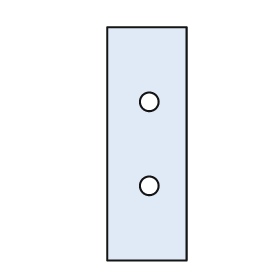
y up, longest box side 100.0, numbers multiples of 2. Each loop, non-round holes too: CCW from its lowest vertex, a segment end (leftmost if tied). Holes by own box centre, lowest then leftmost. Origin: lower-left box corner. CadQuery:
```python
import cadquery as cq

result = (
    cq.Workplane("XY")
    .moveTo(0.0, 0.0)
    .lineTo(34.0, 0.0)
    .lineTo(34.0, 100.0)
    .lineTo(0.0, 100.0)
    .close()
    .moveTo(18.0, 32.0)
    .circle(4.0)
    .moveTo(18.0, 68.0)
    .circle(4.0)
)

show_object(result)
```